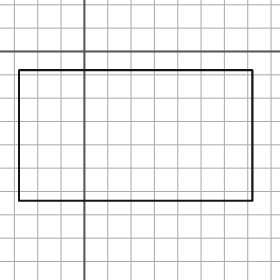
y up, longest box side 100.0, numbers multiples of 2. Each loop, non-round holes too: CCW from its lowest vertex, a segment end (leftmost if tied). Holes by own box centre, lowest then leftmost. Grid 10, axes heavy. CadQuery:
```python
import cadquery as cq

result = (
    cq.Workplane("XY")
    .moveTo(-28.0, -64.0)
    .lineTo(72.0, -64.0)
    .lineTo(72.0, -8.0)
    .lineTo(-28.0, -8.0)
    .close()
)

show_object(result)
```